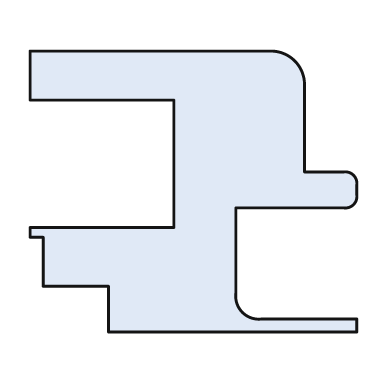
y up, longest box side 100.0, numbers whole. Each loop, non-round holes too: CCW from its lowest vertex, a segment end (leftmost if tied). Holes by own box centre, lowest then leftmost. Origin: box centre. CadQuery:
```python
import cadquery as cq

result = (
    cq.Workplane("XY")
    .moveTo(-26.0, -43.0)
    .lineTo(50.0, -43.0)
    .lineTo(50.0, -39.0)
    .lineTo(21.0, -39.0)
    .threePointArc((15.0, -37.0), (13.0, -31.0))
    .lineTo(13.0, -5.0)
    .lineTo(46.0, -5.0)
    .threePointArc((49.0, -4.0), (50.0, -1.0))
    .lineTo(50.0, 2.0)
    .threePointArc((49.0, 5.0), (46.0, 6.0))
    .lineTo(34.0, 6.0)
    .lineTo(34.0, 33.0)
    .threePointArc((31.0, 40.0), (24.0, 43.0))
    .lineTo(-50.0, 43.0)
    .lineTo(-50.0, 28.0)
    .lineTo(-6.0, 28.0)
    .lineTo(-6.0, -11.0)
    .lineTo(-50.0, -11.0)
    .lineTo(-50.0, -14.0)
    .lineTo(-46.0, -14.0)
    .lineTo(-46.0, -29.0)
    .lineTo(-26.0, -29.0)
    .close()
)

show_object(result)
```